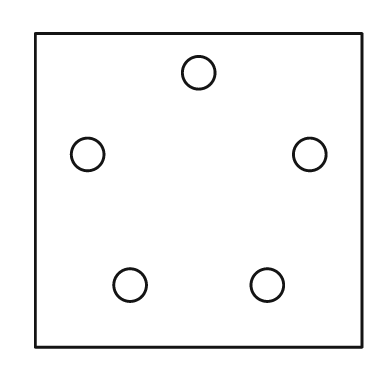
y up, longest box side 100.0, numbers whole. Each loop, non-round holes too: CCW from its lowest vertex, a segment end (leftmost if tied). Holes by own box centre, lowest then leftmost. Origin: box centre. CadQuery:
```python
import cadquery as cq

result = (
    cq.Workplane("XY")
    .moveTo(-50.0, -48.0)
    .lineTo(50.0, -48.0)
    .lineTo(50.0, 48.0)
    .lineTo(-50.0, 48.0)
    .close()
    .moveTo(-21.0, -29.0)
    .circle(5.0)
    .moveTo(21.0, -29.0)
    .circle(5.0)
    .moveTo(-34.0, 11.0)
    .circle(5.0)
    .moveTo(34.0, 11.0)
    .circle(5.0)
    .moveTo(0.0, 36.0)
    .circle(5.0)
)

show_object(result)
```